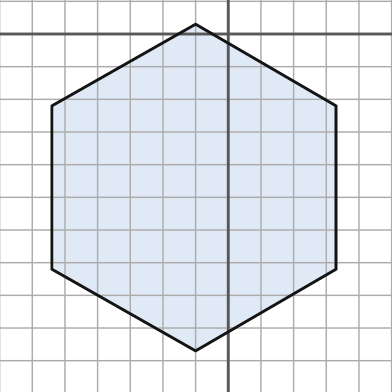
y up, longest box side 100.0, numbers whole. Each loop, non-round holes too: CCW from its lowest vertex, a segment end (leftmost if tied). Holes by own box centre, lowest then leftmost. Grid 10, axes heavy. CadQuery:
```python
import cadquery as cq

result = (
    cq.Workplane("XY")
    .moveTo(-10.0, -97.0)
    .lineTo(33.0, -72.0)
    .lineTo(33.0, -22.0)
    .lineTo(-10.0, 3.0)
    .lineTo(-54.0, -22.0)
    .lineTo(-54.0, -72.0)
    .close()
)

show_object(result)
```